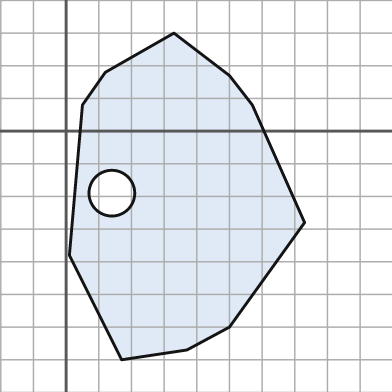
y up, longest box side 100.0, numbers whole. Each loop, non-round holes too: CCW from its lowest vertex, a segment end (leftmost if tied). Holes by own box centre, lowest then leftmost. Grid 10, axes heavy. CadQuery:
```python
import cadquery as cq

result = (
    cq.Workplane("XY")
    .moveTo(17.0, -70.0)
    .lineTo(37.0, -67.0)
    .lineTo(50.0, -60.0)
    .lineTo(73.0, -28.0)
    .lineTo(57.0, 8.0)
    .lineTo(50.0, 17.0)
    .lineTo(33.0, 30.0)
    .lineTo(12.0, 18.0)
    .lineTo(5.0, 8.0)
    .lineTo(1.0, -38.0)
    .close()
    .moveTo(14.0, -19.0)
    .circle(7.0)
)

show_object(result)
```